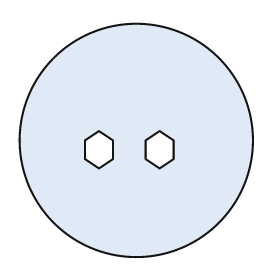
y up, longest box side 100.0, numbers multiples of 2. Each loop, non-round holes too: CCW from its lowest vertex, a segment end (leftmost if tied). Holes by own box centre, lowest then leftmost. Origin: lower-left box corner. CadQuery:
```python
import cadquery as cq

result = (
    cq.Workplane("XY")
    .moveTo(50.0, 50.0)
    .circle(50.0)
    .moveTo(34.0, 38.0)
    .lineTo(40.0, 42.0)
    .lineTo(40.0, 50.0)
    .lineTo(34.0, 54.0)
    .lineTo(28.0, 50.0)
    .lineTo(28.0, 42.0)
    .close()
    .moveTo(60.0, 38.0)
    .lineTo(66.0, 42.0)
    .lineTo(66.0, 50.0)
    .lineTo(60.0, 54.0)
    .lineTo(54.0, 50.0)
    .lineTo(54.0, 42.0)
    .close()
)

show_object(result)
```